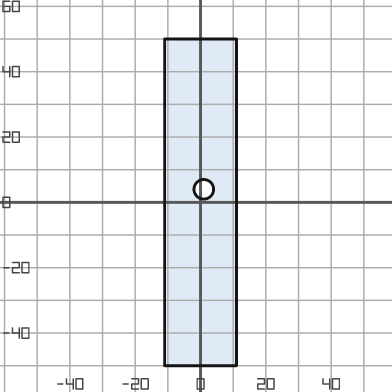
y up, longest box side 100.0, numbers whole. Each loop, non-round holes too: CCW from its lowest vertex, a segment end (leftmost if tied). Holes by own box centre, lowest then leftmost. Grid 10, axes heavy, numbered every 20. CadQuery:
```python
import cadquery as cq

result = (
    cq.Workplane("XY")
    .moveTo(-11.0, -50.0)
    .lineTo(11.0, -50.0)
    .lineTo(11.0, 50.0)
    .lineTo(-11.0, 50.0)
    .close()
    .moveTo(1.0, 4.0)
    .circle(3.0)
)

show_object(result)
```